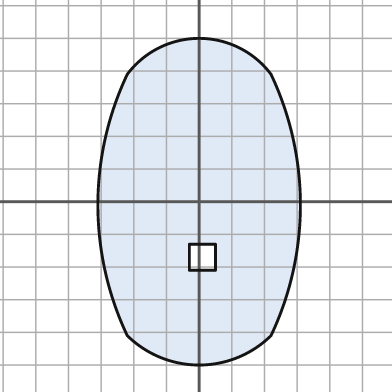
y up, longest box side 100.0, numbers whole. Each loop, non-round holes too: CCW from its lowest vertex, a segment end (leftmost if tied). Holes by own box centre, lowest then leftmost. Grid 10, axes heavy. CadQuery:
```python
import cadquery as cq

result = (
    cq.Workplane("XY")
    .moveTo(-22.0, -41.0)
    .threePointArc((0.0, -50.0), (22.0, -41.0))
    .threePointArc((31.0, -1.0), (22.0, 39.0))
    .threePointArc((0.0, 50.0), (-22.0, 39.0))
    .threePointArc((-31.0, -1.0), (-22.0, -41.0))
    .close()
    .moveTo(-3.0, -21.0)
    .lineTo(5.0, -21.0)
    .lineTo(5.0, -13.0)
    .lineTo(-3.0, -13.0)
    .close()
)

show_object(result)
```